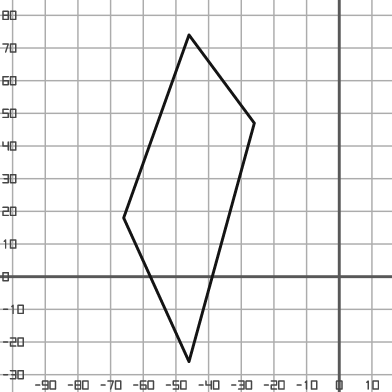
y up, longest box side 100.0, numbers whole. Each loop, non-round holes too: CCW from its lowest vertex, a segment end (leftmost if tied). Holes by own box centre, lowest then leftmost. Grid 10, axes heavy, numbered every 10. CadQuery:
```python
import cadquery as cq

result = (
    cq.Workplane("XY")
    .moveTo(-46.0, -26.0)
    .lineTo(-26.0, 47.0)
    .lineTo(-46.0, 74.0)
    .lineTo(-66.0, 18.0)
    .close()
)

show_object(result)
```